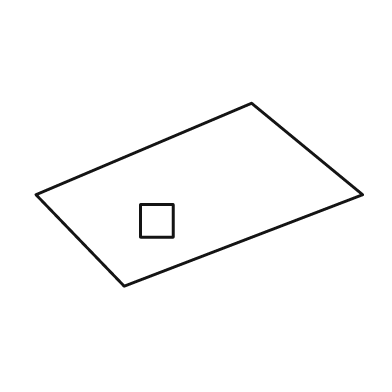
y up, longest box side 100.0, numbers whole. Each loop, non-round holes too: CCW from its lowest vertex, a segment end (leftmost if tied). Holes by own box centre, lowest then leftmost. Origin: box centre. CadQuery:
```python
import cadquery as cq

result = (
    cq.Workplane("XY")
    .moveTo(-23.0, -28.0)
    .lineTo(50.0, 0.0)
    .lineTo(16.0, 28.0)
    .lineTo(-50.0, 0.0)
    .close()
    .moveTo(-18.0, -13.0)
    .lineTo(-8.0, -13.0)
    .lineTo(-8.0, -3.0)
    .lineTo(-18.0, -3.0)
    .close()
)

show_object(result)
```